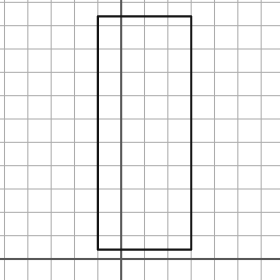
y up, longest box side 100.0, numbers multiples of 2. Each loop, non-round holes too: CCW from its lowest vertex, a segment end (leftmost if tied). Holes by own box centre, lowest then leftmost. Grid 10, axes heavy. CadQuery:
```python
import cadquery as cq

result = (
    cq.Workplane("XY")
    .moveTo(-10.0, 4.0)
    .lineTo(30.0, 4.0)
    .lineTo(30.0, 104.0)
    .lineTo(-10.0, 104.0)
    .close()
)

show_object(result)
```